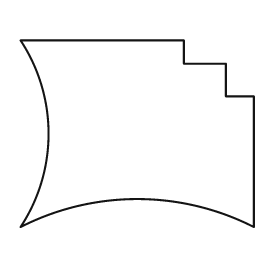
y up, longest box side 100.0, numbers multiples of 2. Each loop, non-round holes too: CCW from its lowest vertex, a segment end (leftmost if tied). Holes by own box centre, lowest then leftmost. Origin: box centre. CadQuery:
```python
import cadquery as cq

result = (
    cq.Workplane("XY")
    .moveTo(-50.0, -40.0)
    .threePointArc((0.0, -28.0), (50.0, -40.0))
    .lineTo(50.0, 16.0)
    .lineTo(38.0, 16.0)
    .lineTo(38.0, 30.0)
    .lineTo(20.0, 30.0)
    .lineTo(20.0, 40.0)
    .lineTo(-50.0, 40.0)
    .threePointArc((-38.0, 0.0), (-50.0, -40.0))
    .close()
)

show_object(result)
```